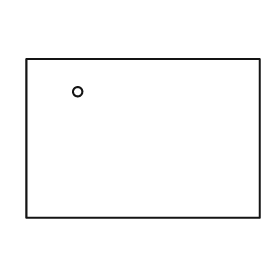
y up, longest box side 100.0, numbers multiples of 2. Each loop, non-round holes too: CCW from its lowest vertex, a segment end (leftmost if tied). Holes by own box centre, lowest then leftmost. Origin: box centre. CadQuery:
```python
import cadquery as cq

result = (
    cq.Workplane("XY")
    .moveTo(-50.0, -34.0)
    .lineTo(50.0, -34.0)
    .lineTo(50.0, 34.0)
    .lineTo(-50.0, 34.0)
    .close()
    .moveTo(-28.0, 20.0)
    .circle(2.0)
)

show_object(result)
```